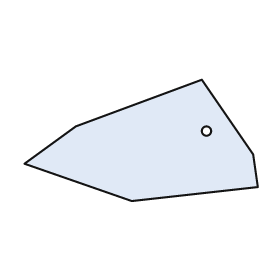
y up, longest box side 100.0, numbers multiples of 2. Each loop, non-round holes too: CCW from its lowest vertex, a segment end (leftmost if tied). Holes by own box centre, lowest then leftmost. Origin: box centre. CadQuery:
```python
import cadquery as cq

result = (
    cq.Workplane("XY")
    .moveTo(-4.0, -26.0)
    .lineTo(50.0, -20.0)
    .lineTo(48.0, -6.0)
    .lineTo(26.0, 26.0)
    .lineTo(-28.0, 6.0)
    .lineTo(-50.0, -10.0)
    .close()
    .moveTo(28.0, 4.0)
    .circle(2.0)
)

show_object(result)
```